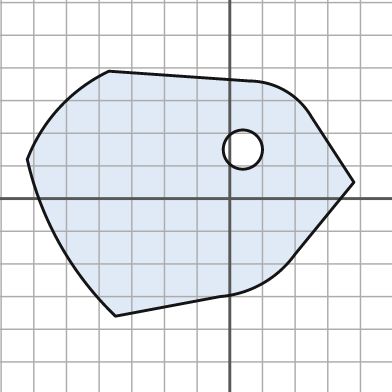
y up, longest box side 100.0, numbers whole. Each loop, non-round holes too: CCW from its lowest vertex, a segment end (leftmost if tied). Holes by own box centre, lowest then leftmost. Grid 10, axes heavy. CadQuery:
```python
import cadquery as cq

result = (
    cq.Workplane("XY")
    .moveTo(-35.0, -36.0)
    .lineTo(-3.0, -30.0)
    .threePointArc((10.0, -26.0), (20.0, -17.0))
    .lineTo(38.0, 5.0)
    .lineTo(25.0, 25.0)
    .threePointArc((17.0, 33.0), (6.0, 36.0))
    .lineTo(-37.0, 39.0)
    .threePointArc((-52.0, 28.0), (-62.0, 12.0))
    .threePointArc((-52.0, -14.0), (-35.0, -36.0))
    .close()
    .moveTo(4.0, 15.0)
    .circle(6.0)
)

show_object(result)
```